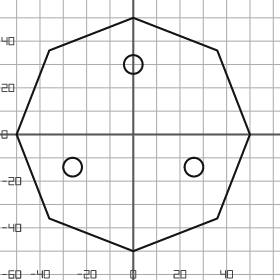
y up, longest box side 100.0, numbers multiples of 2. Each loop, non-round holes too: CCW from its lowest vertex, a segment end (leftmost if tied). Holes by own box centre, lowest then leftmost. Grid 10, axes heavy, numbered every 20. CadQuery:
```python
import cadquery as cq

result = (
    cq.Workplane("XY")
    .moveTo(0.0, -50.0)
    .lineTo(36.0, -36.0)
    .lineTo(50.0, 0.0)
    .lineTo(36.0, 36.0)
    .lineTo(0.0, 50.0)
    .lineTo(-36.0, 36.0)
    .lineTo(-50.0, 0.0)
    .lineTo(-36.0, -36.0)
    .close()
    .moveTo(-26.0, -14.0)
    .circle(4.0)
    .moveTo(26.0, -14.0)
    .circle(4.0)
    .moveTo(0.0, 30.0)
    .circle(4.0)
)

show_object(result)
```